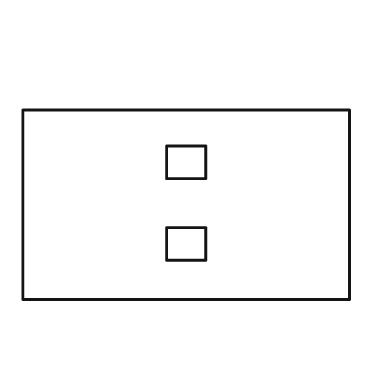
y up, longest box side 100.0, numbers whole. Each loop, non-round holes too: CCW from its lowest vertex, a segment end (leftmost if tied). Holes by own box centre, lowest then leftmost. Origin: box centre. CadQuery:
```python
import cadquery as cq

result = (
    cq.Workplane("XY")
    .moveTo(-50.0, -29.0)
    .lineTo(50.0, -29.0)
    .lineTo(50.0, 29.0)
    .lineTo(-50.0, 29.0)
    .close()
    .moveTo(-6.0, -17.0)
    .lineTo(6.0, -17.0)
    .lineTo(6.0, -7.0)
    .lineTo(-6.0, -7.0)
    .close()
    .moveTo(-6.0, 8.0)
    .lineTo(6.0, 8.0)
    .lineTo(6.0, 18.0)
    .lineTo(-6.0, 18.0)
    .close()
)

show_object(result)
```